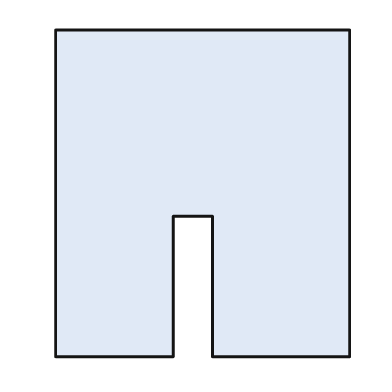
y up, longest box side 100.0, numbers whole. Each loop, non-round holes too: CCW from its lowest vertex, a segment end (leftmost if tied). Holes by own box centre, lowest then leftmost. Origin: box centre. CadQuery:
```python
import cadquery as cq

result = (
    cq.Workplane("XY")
    .moveTo(-45.0, -50.0)
    .lineTo(-9.0, -50.0)
    .lineTo(-9.0, -7.0)
    .lineTo(3.0, -7.0)
    .lineTo(3.0, -50.0)
    .lineTo(45.0, -50.0)
    .lineTo(45.0, 50.0)
    .lineTo(-45.0, 50.0)
    .close()
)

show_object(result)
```